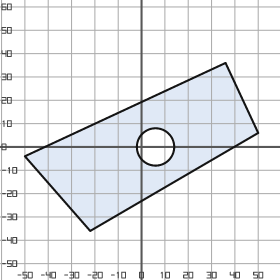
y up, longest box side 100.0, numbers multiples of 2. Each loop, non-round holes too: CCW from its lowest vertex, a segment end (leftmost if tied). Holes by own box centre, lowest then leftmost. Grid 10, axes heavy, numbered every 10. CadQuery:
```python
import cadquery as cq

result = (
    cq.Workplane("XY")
    .moveTo(-22.0, -36.0)
    .lineTo(50.0, 6.0)
    .lineTo(36.0, 36.0)
    .lineTo(-50.0, -4.0)
    .close()
    .moveTo(6.0, 0.0)
    .circle(8.0)
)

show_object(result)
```